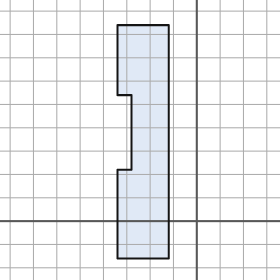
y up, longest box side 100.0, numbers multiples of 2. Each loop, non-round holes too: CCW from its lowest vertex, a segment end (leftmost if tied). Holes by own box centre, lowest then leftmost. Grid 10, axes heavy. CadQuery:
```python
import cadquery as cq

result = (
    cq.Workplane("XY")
    .moveTo(-34.0, -16.0)
    .lineTo(-12.0, -16.0)
    .lineTo(-12.0, 84.0)
    .lineTo(-34.0, 84.0)
    .lineTo(-34.0, 54.0)
    .lineTo(-28.0, 54.0)
    .lineTo(-28.0, 22.0)
    .lineTo(-34.0, 22.0)
    .close()
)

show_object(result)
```